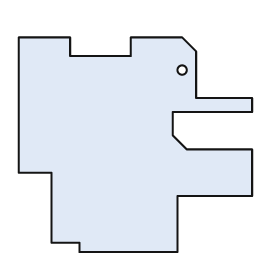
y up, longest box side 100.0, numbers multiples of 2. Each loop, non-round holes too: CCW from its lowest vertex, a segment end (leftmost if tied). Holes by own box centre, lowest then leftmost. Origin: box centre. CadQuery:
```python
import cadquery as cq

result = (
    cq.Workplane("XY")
    .moveTo(-24.0, -46.0)
    .lineTo(18.0, -46.0)
    .lineTo(18.0, -22.0)
    .lineTo(50.0, -22.0)
    .lineTo(50.0, -2.0)
    .lineTo(22.0, -2.0)
    .lineTo(16.0, 4.0)
    .lineTo(16.0, 14.0)
    .lineTo(50.0, 14.0)
    .lineTo(50.0, 20.0)
    .lineTo(26.0, 20.0)
    .lineTo(26.0, 40.0)
    .lineTo(20.0, 46.0)
    .lineTo(-2.0, 46.0)
    .lineTo(-2.0, 38.0)
    .lineTo(-28.0, 38.0)
    .lineTo(-28.0, 46.0)
    .lineTo(-50.0, 46.0)
    .lineTo(-50.0, -12.0)
    .lineTo(-36.0, -12.0)
    .lineTo(-36.0, -42.0)
    .lineTo(-24.0, -42.0)
    .close()
    .moveTo(20.0, 32.0)
    .circle(2.0)
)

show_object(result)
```